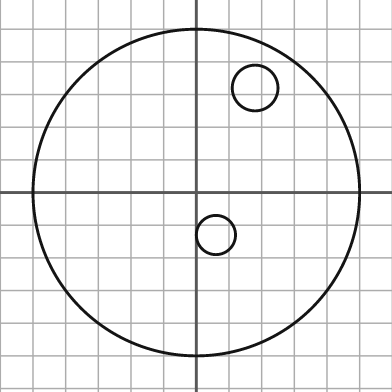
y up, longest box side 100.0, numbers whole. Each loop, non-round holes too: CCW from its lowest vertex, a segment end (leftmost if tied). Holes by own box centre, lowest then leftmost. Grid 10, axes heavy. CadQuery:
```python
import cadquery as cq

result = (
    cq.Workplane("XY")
    .moveTo(0.0, 0.0)
    .circle(50.0)
    .moveTo(6.0, -13.0)
    .circle(6.0)
    .moveTo(18.0, 32.0)
    .circle(7.0)
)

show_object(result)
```